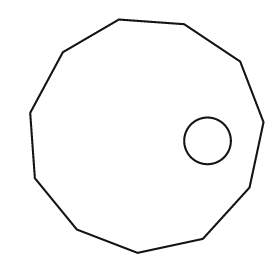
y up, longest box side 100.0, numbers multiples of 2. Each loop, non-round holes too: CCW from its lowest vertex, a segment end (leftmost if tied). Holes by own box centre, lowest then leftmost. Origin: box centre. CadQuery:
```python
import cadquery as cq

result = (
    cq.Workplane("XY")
    .moveTo(-4.0, -50.0)
    .lineTo(24.0, -44.0)
    .lineTo(44.0, -22.0)
    .lineTo(50.0, 6.0)
    .lineTo(40.0, 32.0)
    .lineTo(16.0, 48.0)
    .lineTo(-12.0, 50.0)
    .lineTo(-36.0, 36.0)
    .lineTo(-50.0, 10.0)
    .lineTo(-48.0, -18.0)
    .lineTo(-30.0, -40.0)
    .close()
    .moveTo(26.0, -2.0)
    .circle(10.0)
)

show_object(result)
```